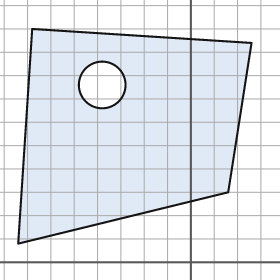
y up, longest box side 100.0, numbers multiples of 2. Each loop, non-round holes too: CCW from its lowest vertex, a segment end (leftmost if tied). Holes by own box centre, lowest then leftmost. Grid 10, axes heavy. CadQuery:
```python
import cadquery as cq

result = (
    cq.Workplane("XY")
    .moveTo(-74.0, 8.0)
    .lineTo(16.0, 30.0)
    .lineTo(26.0, 94.0)
    .lineTo(-68.0, 100.0)
    .close()
    .moveTo(-38.0, 76.0)
    .circle(10.0)
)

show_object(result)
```